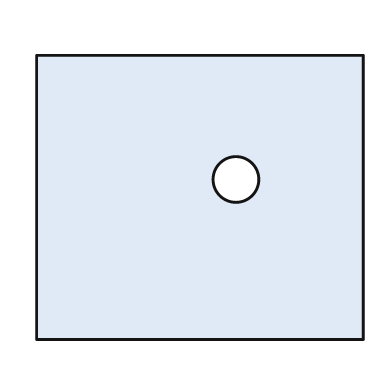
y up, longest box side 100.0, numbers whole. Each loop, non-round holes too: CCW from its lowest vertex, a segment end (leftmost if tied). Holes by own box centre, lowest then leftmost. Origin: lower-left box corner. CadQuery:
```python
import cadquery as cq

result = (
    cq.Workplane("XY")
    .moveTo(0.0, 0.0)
    .lineTo(100.0, 0.0)
    .lineTo(100.0, 87.0)
    .lineTo(0.0, 87.0)
    .close()
    .moveTo(61.0, 49.0)
    .circle(7.0)
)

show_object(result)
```